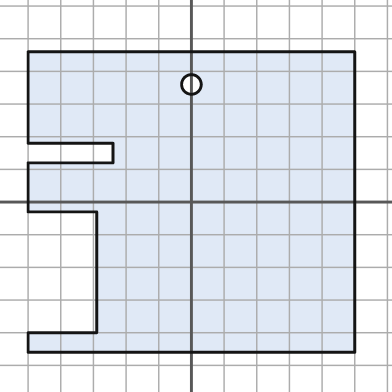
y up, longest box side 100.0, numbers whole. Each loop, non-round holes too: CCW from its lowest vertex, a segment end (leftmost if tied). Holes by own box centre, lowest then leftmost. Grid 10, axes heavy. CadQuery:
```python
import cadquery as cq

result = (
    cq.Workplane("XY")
    .moveTo(-50.0, -46.0)
    .lineTo(50.0, -46.0)
    .lineTo(50.0, 46.0)
    .lineTo(-50.0, 46.0)
    .lineTo(-50.0, 18.0)
    .lineTo(-24.0, 18.0)
    .lineTo(-24.0, 12.0)
    .lineTo(-50.0, 12.0)
    .lineTo(-50.0, -3.0)
    .lineTo(-29.0, -3.0)
    .lineTo(-29.0, -40.0)
    .lineTo(-50.0, -40.0)
    .close()
    .moveTo(0.0, 36.0)
    .circle(3.0)
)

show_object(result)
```